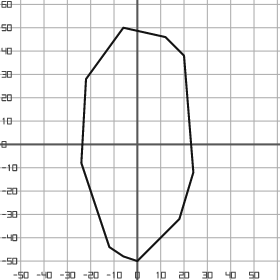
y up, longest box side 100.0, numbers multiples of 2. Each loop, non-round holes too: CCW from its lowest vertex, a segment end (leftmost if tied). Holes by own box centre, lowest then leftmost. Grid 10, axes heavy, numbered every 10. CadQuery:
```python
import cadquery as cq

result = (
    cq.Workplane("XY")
    .moveTo(0.0, -50.0)
    .lineTo(18.0, -32.0)
    .lineTo(24.0, -12.0)
    .lineTo(20.0, 38.0)
    .lineTo(12.0, 46.0)
    .lineTo(-6.0, 50.0)
    .lineTo(-22.0, 28.0)
    .lineTo(-24.0, -8.0)
    .lineTo(-12.0, -44.0)
    .lineTo(-6.0, -48.0)
    .close()
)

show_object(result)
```